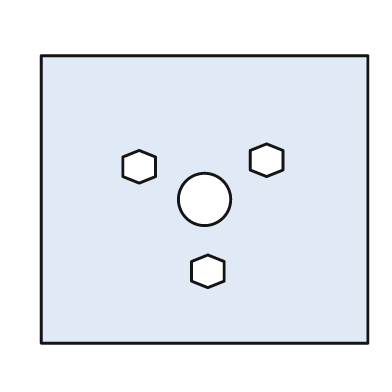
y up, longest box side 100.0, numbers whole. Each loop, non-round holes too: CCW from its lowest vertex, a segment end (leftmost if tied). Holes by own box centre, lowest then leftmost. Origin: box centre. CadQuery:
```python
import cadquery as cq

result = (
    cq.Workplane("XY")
    .moveTo(-50.0, -44.0)
    .lineTo(50.0, -44.0)
    .lineTo(50.0, 44.0)
    .lineTo(-50.0, 44.0)
    .close()
    .moveTo(1.0, -27.0)
    .lineTo(6.0, -25.0)
    .lineTo(6.0, -19.0)
    .lineTo(1.0, -17.0)
    .lineTo(-4.0, -19.0)
    .lineTo(-4.0, -25.0)
    .close()
    .moveTo(0.0, 0.0)
    .circle(8.0)
    .moveTo(-20.0, 5.0)
    .lineTo(-15.0, 7.0)
    .lineTo(-15.0, 13.0)
    .lineTo(-20.0, 15.0)
    .lineTo(-25.0, 13.0)
    .lineTo(-25.0, 7.0)
    .close()
    .moveTo(19.0, 7.0)
    .lineTo(24.0, 9.0)
    .lineTo(24.0, 15.0)
    .lineTo(19.0, 17.0)
    .lineTo(14.0, 15.0)
    .lineTo(14.0, 9.0)
    .close()
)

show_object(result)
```